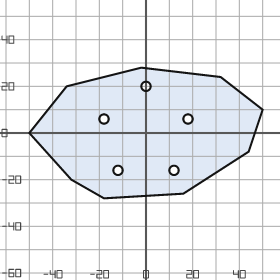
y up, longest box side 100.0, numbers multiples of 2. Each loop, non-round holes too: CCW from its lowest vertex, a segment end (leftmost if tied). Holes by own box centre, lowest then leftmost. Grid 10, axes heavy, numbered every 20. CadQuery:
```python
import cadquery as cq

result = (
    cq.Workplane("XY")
    .moveTo(-18.0, -28.0)
    .lineTo(16.0, -26.0)
    .lineTo(44.0, -8.0)
    .lineTo(50.0, 10.0)
    .lineTo(32.0, 24.0)
    .lineTo(-2.0, 28.0)
    .lineTo(-34.0, 20.0)
    .lineTo(-50.0, 0.0)
    .lineTo(-32.0, -20.0)
    .close()
    .moveTo(-12.0, -16.0)
    .circle(2.0)
    .moveTo(12.0, -16.0)
    .circle(2.0)
    .moveTo(-18.0, 6.0)
    .circle(2.0)
    .moveTo(18.0, 6.0)
    .circle(2.0)
    .moveTo(0.0, 20.0)
    .circle(2.0)
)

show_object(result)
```